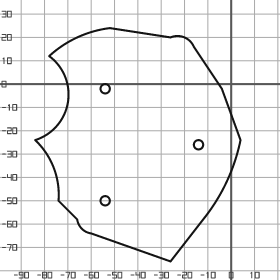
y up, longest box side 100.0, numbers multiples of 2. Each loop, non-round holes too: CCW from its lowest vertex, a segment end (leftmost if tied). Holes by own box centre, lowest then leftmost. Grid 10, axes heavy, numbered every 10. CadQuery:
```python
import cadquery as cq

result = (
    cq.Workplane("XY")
    .moveTo(-26.0, -76.0)
    .lineTo(-12.0, -58.0)
    .threePointArc((-2.0, -42.0), (4.0, -24.0))
    .lineTo(-4.0, -2.0)
    .lineTo(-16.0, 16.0)
    .threePointArc((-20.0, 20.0), (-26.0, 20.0))
    .lineTo(-52.0, 24.0)
    .threePointArc((-66.0, 20.0), (-78.0, 12.0))
    .threePointArc((-70.0, -8.0), (-84.0, -24.0))
    .threePointArc((-76.0, -36.0), (-74.0, -50.0))
    .lineTo(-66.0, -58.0)
    .threePointArc((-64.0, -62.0), (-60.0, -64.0))
    .close()
    .moveTo(-54.0, -50.0)
    .circle(2.0)
    .moveTo(-14.0, -26.0)
    .circle(2.0)
    .moveTo(-54.0, -2.0)
    .circle(2.0)
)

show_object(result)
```